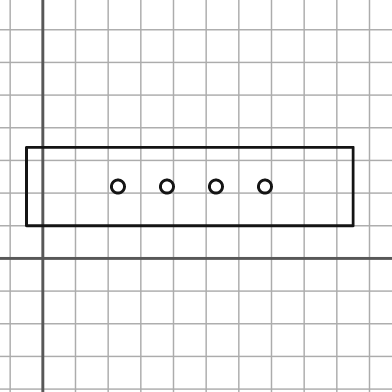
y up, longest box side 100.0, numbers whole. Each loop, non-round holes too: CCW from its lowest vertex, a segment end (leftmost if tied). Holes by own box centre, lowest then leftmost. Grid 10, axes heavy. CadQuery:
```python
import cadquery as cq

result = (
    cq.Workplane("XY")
    .moveTo(-5.0, 10.0)
    .lineTo(95.0, 10.0)
    .lineTo(95.0, 34.0)
    .lineTo(-5.0, 34.0)
    .close()
    .moveTo(23.0, 22.0)
    .circle(2.0)
    .moveTo(38.0, 22.0)
    .circle(2.0)
    .moveTo(53.0, 22.0)
    .circle(2.0)
    .moveTo(68.0, 22.0)
    .circle(2.0)
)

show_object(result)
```